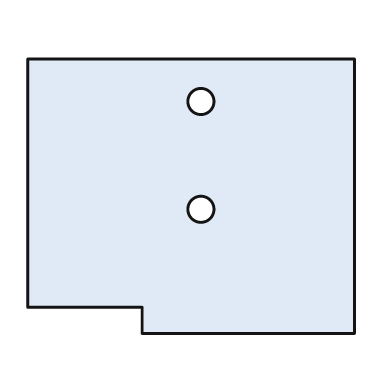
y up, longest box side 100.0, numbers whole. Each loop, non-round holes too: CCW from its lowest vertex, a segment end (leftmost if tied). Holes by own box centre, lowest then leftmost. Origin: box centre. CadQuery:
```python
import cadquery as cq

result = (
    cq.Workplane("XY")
    .moveTo(-15.0, -42.0)
    .lineTo(50.0, -42.0)
    .lineTo(50.0, 42.0)
    .lineTo(-50.0, 42.0)
    .lineTo(-50.0, -34.0)
    .lineTo(-15.0, -34.0)
    .close()
    .moveTo(3.0, -4.0)
    .circle(4.0)
    .moveTo(3.0, 29.0)
    .circle(4.0)
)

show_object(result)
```